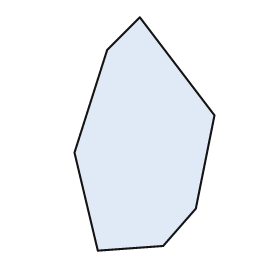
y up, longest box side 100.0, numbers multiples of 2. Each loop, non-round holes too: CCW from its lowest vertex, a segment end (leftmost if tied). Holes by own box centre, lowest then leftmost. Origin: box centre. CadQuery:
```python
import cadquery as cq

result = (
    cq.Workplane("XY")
    .moveTo(-20.0, -50.0)
    .lineTo(8.0, -48.0)
    .lineTo(22.0, -32.0)
    .lineTo(30.0, 8.0)
    .lineTo(-2.0, 50.0)
    .lineTo(-16.0, 36.0)
    .lineTo(-30.0, -8.0)
    .close()
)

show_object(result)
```